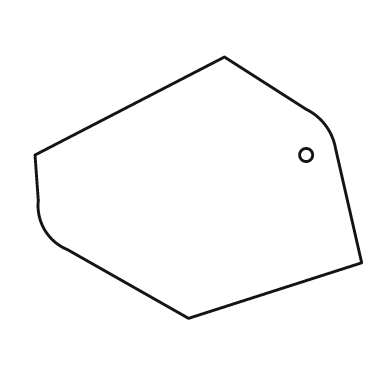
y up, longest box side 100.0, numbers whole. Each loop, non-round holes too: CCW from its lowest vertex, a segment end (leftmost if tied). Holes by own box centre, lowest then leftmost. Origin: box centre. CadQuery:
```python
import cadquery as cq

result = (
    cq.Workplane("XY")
    .moveTo(-3.0, -40.0)
    .lineTo(50.0, -23.0)
    .lineTo(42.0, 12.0)
    .threePointArc((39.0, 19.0), (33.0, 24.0))
    .lineTo(8.0, 40.0)
    .lineTo(-50.0, 10.0)
    .lineTo(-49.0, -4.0)
    .threePointArc((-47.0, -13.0), (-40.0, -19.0))
    .close()
    .moveTo(33.0, 10.0)
    .circle(2.0)
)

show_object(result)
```